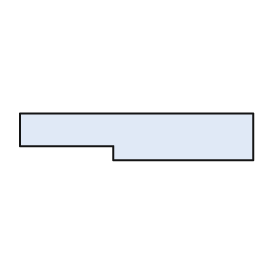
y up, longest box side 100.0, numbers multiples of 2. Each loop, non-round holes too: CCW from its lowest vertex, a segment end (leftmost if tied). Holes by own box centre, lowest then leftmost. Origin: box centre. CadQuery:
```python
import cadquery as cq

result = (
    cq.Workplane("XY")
    .moveTo(-10.0, -10.0)
    .lineTo(50.0, -10.0)
    .lineTo(50.0, 10.0)
    .lineTo(-50.0, 10.0)
    .lineTo(-50.0, -4.0)
    .lineTo(-10.0, -4.0)
    .close()
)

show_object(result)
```